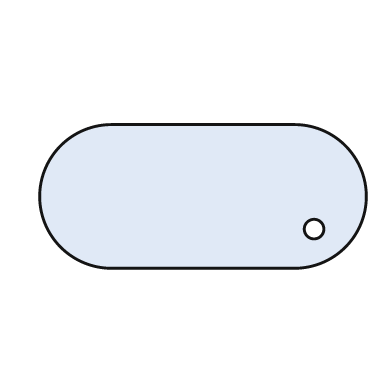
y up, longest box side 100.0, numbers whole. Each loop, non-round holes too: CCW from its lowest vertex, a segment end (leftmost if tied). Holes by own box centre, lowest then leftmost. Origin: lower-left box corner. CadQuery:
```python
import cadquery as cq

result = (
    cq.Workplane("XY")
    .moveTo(22.0, 0.0)
    .lineTo(78.0, 0.0)
    .threePointArc((100.0, 22.0), (78.0, 44.0))
    .lineTo(22.0, 44.0)
    .threePointArc((0.0, 22.0), (22.0, 0.0))
    .close()
    .moveTo(84.0, 12.0)
    .circle(3.0)
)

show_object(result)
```